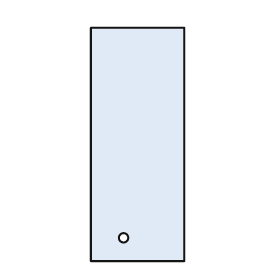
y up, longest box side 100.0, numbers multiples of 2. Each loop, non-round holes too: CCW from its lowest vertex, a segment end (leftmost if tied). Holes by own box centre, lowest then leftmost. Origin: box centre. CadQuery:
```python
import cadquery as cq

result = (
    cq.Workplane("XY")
    .moveTo(-20.0, -50.0)
    .lineTo(20.0, -50.0)
    .lineTo(20.0, 50.0)
    .lineTo(-20.0, 50.0)
    .close()
    .moveTo(-6.0, -40.0)
    .circle(2.0)
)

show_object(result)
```